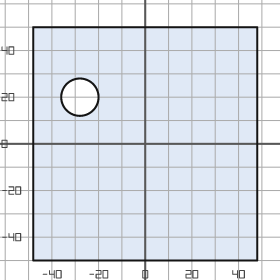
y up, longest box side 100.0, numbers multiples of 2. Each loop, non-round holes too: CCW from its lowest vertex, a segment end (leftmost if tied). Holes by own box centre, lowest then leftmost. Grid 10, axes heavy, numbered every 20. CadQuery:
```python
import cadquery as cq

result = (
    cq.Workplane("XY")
    .moveTo(-48.0, -50.0)
    .lineTo(48.0, -50.0)
    .lineTo(48.0, 50.0)
    .lineTo(-48.0, 50.0)
    .close()
    .moveTo(-28.0, 20.0)
    .circle(8.0)
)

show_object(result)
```